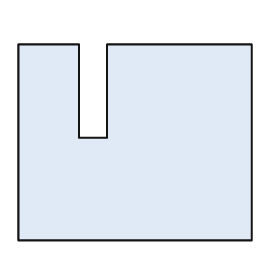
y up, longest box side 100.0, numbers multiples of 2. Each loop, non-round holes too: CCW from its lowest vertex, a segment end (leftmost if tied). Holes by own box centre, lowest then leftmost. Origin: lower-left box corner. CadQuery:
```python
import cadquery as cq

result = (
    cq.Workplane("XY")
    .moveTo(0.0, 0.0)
    .lineTo(100.0, 0.0)
    .lineTo(100.0, 84.0)
    .lineTo(38.0, 84.0)
    .lineTo(38.0, 44.0)
    .lineTo(26.0, 44.0)
    .lineTo(26.0, 84.0)
    .lineTo(0.0, 84.0)
    .close()
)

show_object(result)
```